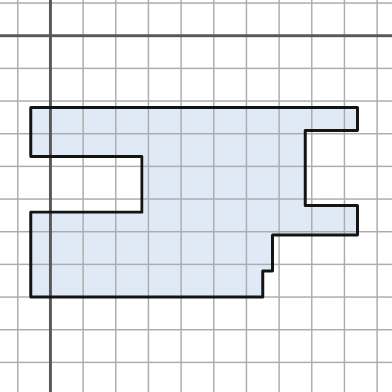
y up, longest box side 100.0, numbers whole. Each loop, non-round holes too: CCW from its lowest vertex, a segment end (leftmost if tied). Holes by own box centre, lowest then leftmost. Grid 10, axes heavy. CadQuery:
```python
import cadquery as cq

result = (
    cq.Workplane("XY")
    .moveTo(-6.0, -80.0)
    .lineTo(65.0, -80.0)
    .lineTo(65.0, -72.0)
    .lineTo(68.0, -72.0)
    .lineTo(68.0, -61.0)
    .lineTo(94.0, -61.0)
    .lineTo(94.0, -52.0)
    .lineTo(78.0, -52.0)
    .lineTo(78.0, -29.0)
    .lineTo(94.0, -29.0)
    .lineTo(94.0, -22.0)
    .lineTo(-6.0, -22.0)
    .lineTo(-6.0, -37.0)
    .lineTo(28.0, -37.0)
    .lineTo(28.0, -54.0)
    .lineTo(-6.0, -54.0)
    .close()
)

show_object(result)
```